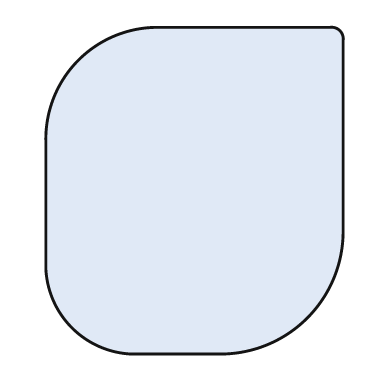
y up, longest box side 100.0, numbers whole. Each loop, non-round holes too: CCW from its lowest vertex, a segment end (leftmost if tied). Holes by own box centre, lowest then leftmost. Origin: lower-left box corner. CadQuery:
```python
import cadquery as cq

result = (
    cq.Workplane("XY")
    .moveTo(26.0, 0.0)
    .lineTo(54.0, 0.0)
    .threePointArc((80.0, 11.0), (91.0, 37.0))
    .lineTo(91.0, 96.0)
    .threePointArc((90.0, 99.0), (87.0, 100.0))
    .lineTo(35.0, 100.0)
    .threePointArc((10.0, 90.0), (0.0, 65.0))
    .lineTo(0.0, 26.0)
    .threePointArc((8.0, 8.0), (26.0, 0.0))
    .close()
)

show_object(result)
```